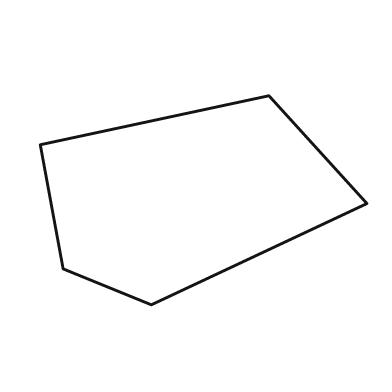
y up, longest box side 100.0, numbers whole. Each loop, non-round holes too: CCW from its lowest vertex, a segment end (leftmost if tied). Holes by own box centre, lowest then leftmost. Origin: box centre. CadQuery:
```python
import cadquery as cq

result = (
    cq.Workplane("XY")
    .moveTo(-16.0, -32.0)
    .lineTo(50.0, -1.0)
    .lineTo(20.0, 32.0)
    .lineTo(-50.0, 17.0)
    .lineTo(-43.0, -21.0)
    .close()
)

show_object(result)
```